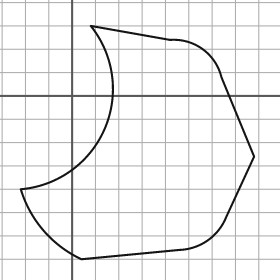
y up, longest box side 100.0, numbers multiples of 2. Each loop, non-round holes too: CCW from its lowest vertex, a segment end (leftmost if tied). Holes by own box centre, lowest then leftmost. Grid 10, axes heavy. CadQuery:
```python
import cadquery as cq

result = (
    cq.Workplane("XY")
    .moveTo(4.0, -70.0)
    .lineTo(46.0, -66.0)
    .threePointArc((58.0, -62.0), (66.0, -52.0))
    .lineTo(78.0, -26.0)
    .lineTo(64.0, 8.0)
    .threePointArc((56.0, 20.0), (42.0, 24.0))
    .lineTo(8.0, 30.0)
    .threePointArc((14.0, -14.0), (-22.0, -40.0))
    .threePointArc((-12.0, -58.0), (4.0, -70.0))
    .close()
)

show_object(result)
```